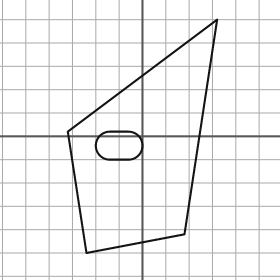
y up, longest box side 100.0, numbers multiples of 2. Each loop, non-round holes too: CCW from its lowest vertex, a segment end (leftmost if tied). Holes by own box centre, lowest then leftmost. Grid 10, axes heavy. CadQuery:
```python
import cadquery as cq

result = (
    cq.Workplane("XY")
    .moveTo(-24.0, -50.0)
    .lineTo(18.0, -42.0)
    .lineTo(32.0, 50.0)
    .lineTo(-32.0, 2.0)
    .close()
    .moveTo(-14.0, -10.0)
    .lineTo(-6.0, -10.0)
    .threePointArc((0.0, -4.0), (-6.0, 2.0))
    .lineTo(-14.0, 2.0)
    .threePointArc((-20.0, -4.0), (-14.0, -10.0))
    .close()
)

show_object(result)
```